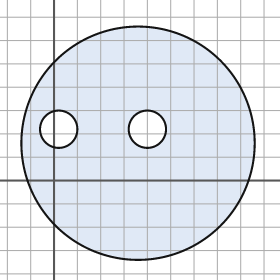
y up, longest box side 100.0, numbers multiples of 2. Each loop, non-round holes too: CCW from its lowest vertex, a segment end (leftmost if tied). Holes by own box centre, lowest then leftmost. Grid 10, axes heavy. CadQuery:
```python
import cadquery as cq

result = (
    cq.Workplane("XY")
    .moveTo(36.0, 16.0)
    .circle(50.0)
    .moveTo(2.0, 22.0)
    .circle(8.0)
    .moveTo(40.0, 22.0)
    .circle(8.0)
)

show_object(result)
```